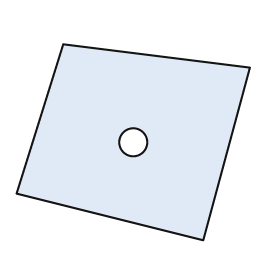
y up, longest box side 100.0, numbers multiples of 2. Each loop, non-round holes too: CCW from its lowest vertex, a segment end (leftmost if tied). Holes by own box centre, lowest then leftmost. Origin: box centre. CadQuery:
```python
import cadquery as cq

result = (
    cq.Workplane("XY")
    .moveTo(30.0, -42.0)
    .lineTo(50.0, 32.0)
    .lineTo(-30.0, 42.0)
    .lineTo(-50.0, -22.0)
    .close()
    .moveTo(0.0, 0.0)
    .circle(6.0)
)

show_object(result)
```